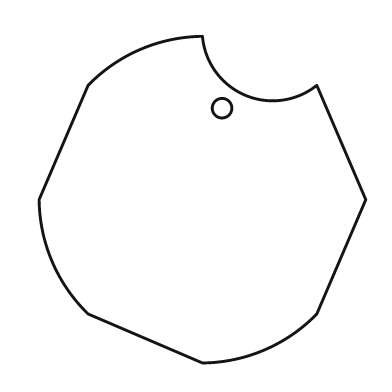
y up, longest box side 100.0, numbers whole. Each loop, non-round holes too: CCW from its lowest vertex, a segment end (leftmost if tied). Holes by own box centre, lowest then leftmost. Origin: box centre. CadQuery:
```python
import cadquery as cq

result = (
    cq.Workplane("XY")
    .moveTo(0.0, -50.0)
    .threePointArc((19.0, -46.0), (35.0, -35.0))
    .lineTo(50.0, 0.0)
    .lineTo(35.0, 35.0)
    .threePointArc((13.0, 32.0), (0.0, 50.0))
    .threePointArc((-19.0, 46.0), (-35.0, 35.0))
    .lineTo(-50.0, 0.0)
    .threePointArc((-46.0, -19.0), (-35.0, -35.0))
    .close()
    .moveTo(6.0, 28.0)
    .circle(3.0)
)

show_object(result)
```